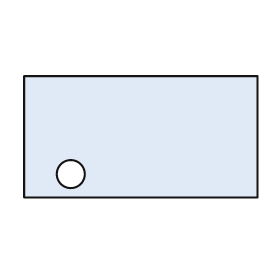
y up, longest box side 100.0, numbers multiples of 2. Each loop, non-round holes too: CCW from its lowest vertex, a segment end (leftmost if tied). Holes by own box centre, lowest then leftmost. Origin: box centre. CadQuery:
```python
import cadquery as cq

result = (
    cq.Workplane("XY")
    .moveTo(-50.0, -26.0)
    .lineTo(50.0, -26.0)
    .lineTo(50.0, 26.0)
    .lineTo(-50.0, 26.0)
    .close()
    .moveTo(-30.0, -16.0)
    .circle(6.0)
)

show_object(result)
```